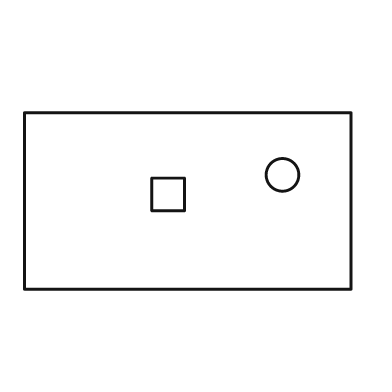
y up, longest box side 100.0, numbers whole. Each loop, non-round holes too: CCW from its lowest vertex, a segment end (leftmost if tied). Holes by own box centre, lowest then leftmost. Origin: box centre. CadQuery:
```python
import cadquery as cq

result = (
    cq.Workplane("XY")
    .moveTo(-50.0, -27.0)
    .lineTo(50.0, -27.0)
    .lineTo(50.0, 27.0)
    .lineTo(-50.0, 27.0)
    .close()
    .moveTo(-11.0, -3.0)
    .lineTo(-1.0, -3.0)
    .lineTo(-1.0, 7.0)
    .lineTo(-11.0, 7.0)
    .close()
    .moveTo(29.0, 8.0)
    .circle(5.0)
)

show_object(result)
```